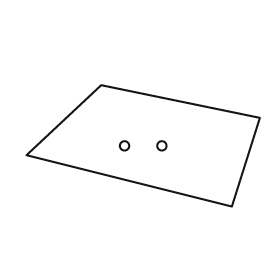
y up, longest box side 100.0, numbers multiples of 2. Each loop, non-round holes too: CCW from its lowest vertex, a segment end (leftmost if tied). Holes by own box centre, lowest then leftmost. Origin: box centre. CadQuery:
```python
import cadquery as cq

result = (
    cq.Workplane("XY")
    .moveTo(38.0, -26.0)
    .lineTo(50.0, 12.0)
    .lineTo(-18.0, 26.0)
    .lineTo(-50.0, -4.0)
    .close()
    .moveTo(-8.0, 0.0)
    .circle(2.0)
    .moveTo(8.0, 0.0)
    .circle(2.0)
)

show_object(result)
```